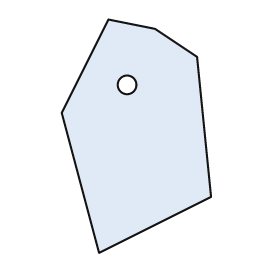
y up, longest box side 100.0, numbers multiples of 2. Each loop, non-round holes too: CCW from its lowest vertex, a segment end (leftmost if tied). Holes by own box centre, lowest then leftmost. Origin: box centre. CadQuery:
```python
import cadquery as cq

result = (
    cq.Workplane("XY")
    .moveTo(-16.0, -50.0)
    .lineTo(32.0, -26.0)
    .lineTo(26.0, 34.0)
    .lineTo(8.0, 46.0)
    .lineTo(-12.0, 50.0)
    .lineTo(-32.0, 10.0)
    .close()
    .moveTo(-4.0, 22.0)
    .circle(4.0)
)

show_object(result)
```